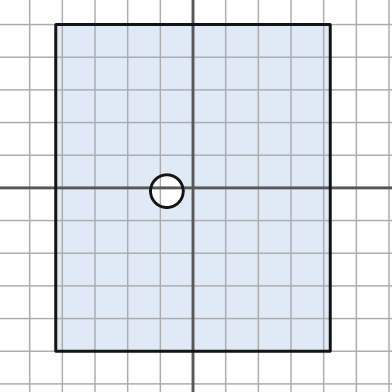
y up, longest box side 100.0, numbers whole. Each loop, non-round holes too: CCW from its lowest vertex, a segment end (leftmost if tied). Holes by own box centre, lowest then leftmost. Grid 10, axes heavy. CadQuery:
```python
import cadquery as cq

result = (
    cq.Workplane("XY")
    .moveTo(-42.0, -50.0)
    .lineTo(42.0, -50.0)
    .lineTo(42.0, 50.0)
    .lineTo(-42.0, 50.0)
    .close()
    .moveTo(-8.0, -1.0)
    .circle(5.0)
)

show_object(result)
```